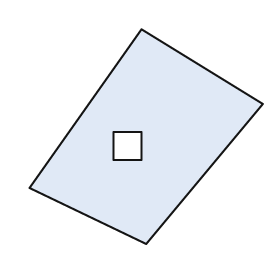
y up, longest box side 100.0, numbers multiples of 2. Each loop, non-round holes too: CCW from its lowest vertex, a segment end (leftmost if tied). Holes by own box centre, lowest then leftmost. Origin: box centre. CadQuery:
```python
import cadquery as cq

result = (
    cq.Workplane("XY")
    .moveTo(0.0, -46.0)
    .lineTo(50.0, 14.0)
    .lineTo(-2.0, 46.0)
    .lineTo(-50.0, -22.0)
    .close()
    .moveTo(-14.0, -10.0)
    .lineTo(-2.0, -10.0)
    .lineTo(-2.0, 2.0)
    .lineTo(-14.0, 2.0)
    .close()
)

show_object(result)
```